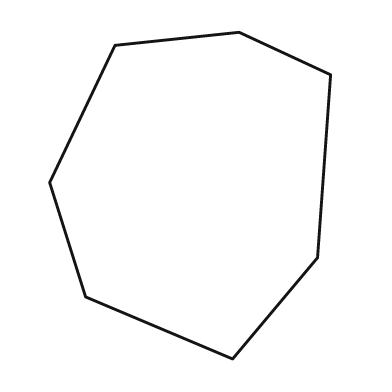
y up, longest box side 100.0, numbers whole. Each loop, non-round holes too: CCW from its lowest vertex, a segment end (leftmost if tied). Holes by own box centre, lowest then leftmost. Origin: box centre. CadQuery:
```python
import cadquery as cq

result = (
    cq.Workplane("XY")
    .moveTo(13.0, -50.0)
    .lineTo(39.0, -19.0)
    .lineTo(43.0, 37.0)
    .lineTo(15.0, 50.0)
    .lineTo(-23.0, 46.0)
    .lineTo(-43.0, 4.0)
    .lineTo(-32.0, -31.0)
    .close()
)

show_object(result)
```